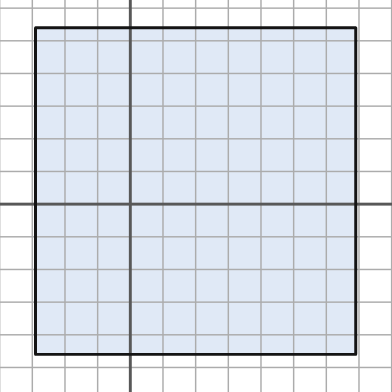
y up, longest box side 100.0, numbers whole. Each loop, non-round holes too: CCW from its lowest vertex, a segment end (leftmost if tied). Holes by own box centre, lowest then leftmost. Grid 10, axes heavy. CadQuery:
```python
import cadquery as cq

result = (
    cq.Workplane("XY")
    .moveTo(-29.0, -46.0)
    .lineTo(69.0, -46.0)
    .lineTo(69.0, 54.0)
    .lineTo(-29.0, 54.0)
    .close()
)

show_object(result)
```